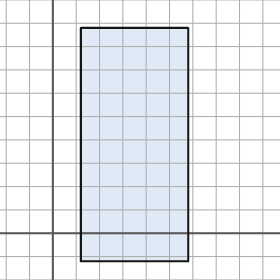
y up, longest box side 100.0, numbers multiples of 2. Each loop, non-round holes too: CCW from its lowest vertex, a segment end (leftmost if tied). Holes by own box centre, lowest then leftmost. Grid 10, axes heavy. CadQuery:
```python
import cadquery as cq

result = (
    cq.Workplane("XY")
    .moveTo(12.0, -12.0)
    .lineTo(58.0, -12.0)
    .lineTo(58.0, 88.0)
    .lineTo(12.0, 88.0)
    .close()
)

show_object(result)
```